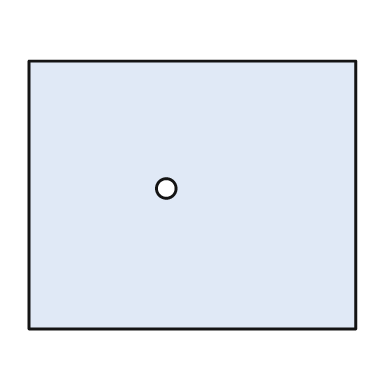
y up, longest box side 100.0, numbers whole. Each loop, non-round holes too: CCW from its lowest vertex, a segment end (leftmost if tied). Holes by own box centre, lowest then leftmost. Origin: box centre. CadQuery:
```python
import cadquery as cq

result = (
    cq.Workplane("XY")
    .moveTo(-50.0, -41.0)
    .lineTo(50.0, -41.0)
    .lineTo(50.0, 41.0)
    .lineTo(-50.0, 41.0)
    .close()
    .moveTo(-8.0, 2.0)
    .circle(3.0)
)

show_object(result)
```